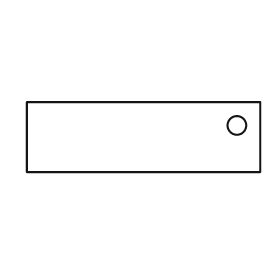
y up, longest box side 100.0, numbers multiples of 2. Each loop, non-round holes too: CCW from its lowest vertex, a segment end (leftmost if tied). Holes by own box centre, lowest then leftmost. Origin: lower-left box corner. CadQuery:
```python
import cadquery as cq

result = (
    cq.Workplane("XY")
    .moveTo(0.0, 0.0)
    .lineTo(100.0, 0.0)
    .lineTo(100.0, 30.0)
    .lineTo(0.0, 30.0)
    .close()
    .moveTo(90.0, 20.0)
    .circle(4.0)
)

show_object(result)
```